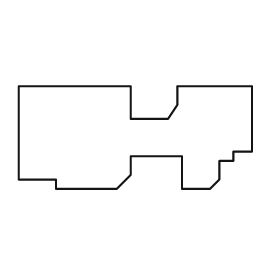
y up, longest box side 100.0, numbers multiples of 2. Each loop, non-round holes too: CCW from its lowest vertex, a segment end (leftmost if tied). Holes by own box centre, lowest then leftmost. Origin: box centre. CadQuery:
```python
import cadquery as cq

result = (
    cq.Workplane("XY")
    .moveTo(-34.0, -22.0)
    .lineTo(-8.0, -22.0)
    .lineTo(-2.0, -16.0)
    .lineTo(-2.0, -8.0)
    .lineTo(20.0, -8.0)
    .lineTo(20.0, -22.0)
    .lineTo(32.0, -22.0)
    .lineTo(36.0, -18.0)
    .lineTo(36.0, -10.0)
    .lineTo(42.0, -10.0)
    .lineTo(42.0, -6.0)
    .lineTo(50.0, -6.0)
    .lineTo(50.0, 22.0)
    .lineTo(18.0, 22.0)
    .lineTo(18.0, 14.0)
    .lineTo(14.0, 8.0)
    .lineTo(-2.0, 8.0)
    .lineTo(-2.0, 22.0)
    .lineTo(-50.0, 22.0)
    .lineTo(-50.0, -18.0)
    .lineTo(-34.0, -18.0)
    .close()
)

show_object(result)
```